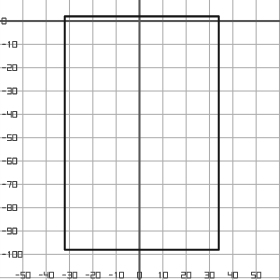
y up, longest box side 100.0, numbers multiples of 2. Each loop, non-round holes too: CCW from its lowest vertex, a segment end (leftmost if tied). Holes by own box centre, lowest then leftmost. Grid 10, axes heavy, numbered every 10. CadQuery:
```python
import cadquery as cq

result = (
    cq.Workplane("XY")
    .moveTo(-32.0, -98.0)
    .lineTo(34.0, -98.0)
    .lineTo(34.0, 2.0)
    .lineTo(-32.0, 2.0)
    .close()
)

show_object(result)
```